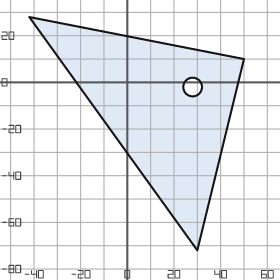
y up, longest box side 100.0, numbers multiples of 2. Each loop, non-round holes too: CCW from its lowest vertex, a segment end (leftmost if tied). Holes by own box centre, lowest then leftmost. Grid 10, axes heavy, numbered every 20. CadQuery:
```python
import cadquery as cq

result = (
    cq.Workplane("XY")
    .moveTo(30.0, -72.0)
    .lineTo(50.0, 10.0)
    .lineTo(-42.0, 28.0)
    .close()
    .moveTo(28.0, -2.0)
    .circle(4.0)
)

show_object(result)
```